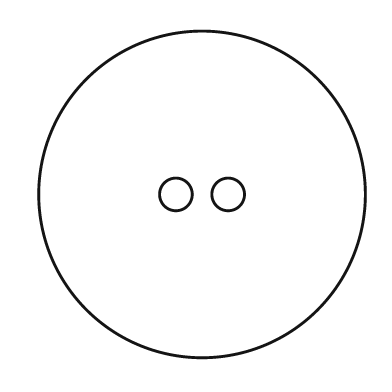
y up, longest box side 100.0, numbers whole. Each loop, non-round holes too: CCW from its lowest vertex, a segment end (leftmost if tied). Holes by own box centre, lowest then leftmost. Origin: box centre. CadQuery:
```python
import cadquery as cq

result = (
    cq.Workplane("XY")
    .moveTo(0.0, 0.0)
    .circle(50.0)
    .moveTo(-8.0, 0.0)
    .circle(5.0)
    .moveTo(8.0, 0.0)
    .circle(5.0)
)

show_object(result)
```